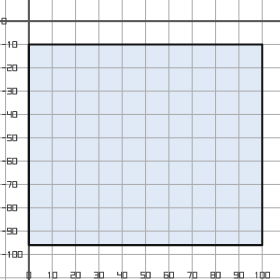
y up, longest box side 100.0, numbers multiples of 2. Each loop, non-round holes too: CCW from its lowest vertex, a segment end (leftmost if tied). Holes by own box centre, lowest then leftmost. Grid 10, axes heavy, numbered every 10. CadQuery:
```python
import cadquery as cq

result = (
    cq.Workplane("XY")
    .moveTo(0.0, -96.0)
    .lineTo(100.0, -96.0)
    .lineTo(100.0, -10.0)
    .lineTo(0.0, -10.0)
    .close()
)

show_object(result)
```